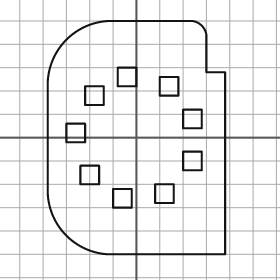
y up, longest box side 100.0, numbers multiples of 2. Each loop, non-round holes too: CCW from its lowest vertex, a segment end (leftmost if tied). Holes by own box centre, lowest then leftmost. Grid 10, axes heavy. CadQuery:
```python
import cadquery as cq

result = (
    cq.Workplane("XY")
    .moveTo(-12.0, -50.0)
    .lineTo(38.0, -50.0)
    .lineTo(38.0, 28.0)
    .lineTo(30.0, 28.0)
    .lineTo(30.0, 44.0)
    .threePointArc((28.0, 48.0), (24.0, 50.0))
    .lineTo(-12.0, 50.0)
    .threePointArc((-30.0, 42.0), (-38.0, 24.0))
    .lineTo(-38.0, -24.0)
    .threePointArc((-30.0, -42.0), (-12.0, -50.0))
    .close()
    .moveTo(-10.0, -30.0)
    .lineTo(-2.0, -30.0)
    .lineTo(-2.0, -22.0)
    .lineTo(-10.0, -22.0)
    .close()
    .moveTo(8.0, -28.0)
    .lineTo(16.0, -28.0)
    .lineTo(16.0, -20.0)
    .lineTo(8.0, -20.0)
    .close()
    .moveTo(-24.0, -20.0)
    .lineTo(-16.0, -20.0)
    .lineTo(-16.0, -12.0)
    .lineTo(-24.0, -12.0)
    .close()
    .moveTo(20.0, -14.0)
    .lineTo(28.0, -14.0)
    .lineTo(28.0, -6.0)
    .lineTo(20.0, -6.0)
    .close()
    .moveTo(-30.0, -2.0)
    .lineTo(-22.0, -2.0)
    .lineTo(-22.0, 6.0)
    .lineTo(-30.0, 6.0)
    .close()
    .moveTo(20.0, 4.0)
    .lineTo(28.0, 4.0)
    .lineTo(28.0, 12.0)
    .lineTo(20.0, 12.0)
    .close()
    .moveTo(-22.0, 14.0)
    .lineTo(-14.0, 14.0)
    .lineTo(-14.0, 22.0)
    .lineTo(-22.0, 22.0)
    .close()
    .moveTo(10.0, 18.0)
    .lineTo(18.0, 18.0)
    .lineTo(18.0, 26.0)
    .lineTo(10.0, 26.0)
    .close()
    .moveTo(-8.0, 22.0)
    .lineTo(0.0, 22.0)
    .lineTo(0.0, 30.0)
    .lineTo(-8.0, 30.0)
    .close()
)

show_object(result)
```